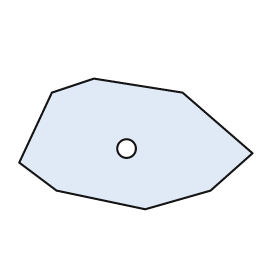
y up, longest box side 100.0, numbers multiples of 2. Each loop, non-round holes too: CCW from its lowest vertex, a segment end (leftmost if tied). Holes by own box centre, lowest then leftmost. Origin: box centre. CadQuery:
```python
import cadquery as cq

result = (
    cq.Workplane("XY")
    .moveTo(4.0, -28.0)
    .lineTo(32.0, -20.0)
    .lineTo(50.0, -4.0)
    .lineTo(20.0, 22.0)
    .lineTo(-18.0, 28.0)
    .lineTo(-36.0, 22.0)
    .lineTo(-50.0, -8.0)
    .lineTo(-34.0, -20.0)
    .close()
    .moveTo(-4.0, -2.0)
    .circle(4.0)
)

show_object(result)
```